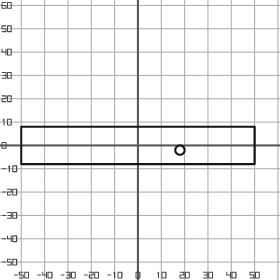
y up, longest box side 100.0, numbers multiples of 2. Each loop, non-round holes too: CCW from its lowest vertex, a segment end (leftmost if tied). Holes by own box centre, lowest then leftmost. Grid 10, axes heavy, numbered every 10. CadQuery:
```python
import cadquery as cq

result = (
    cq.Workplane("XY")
    .moveTo(-50.0, -8.0)
    .lineTo(50.0, -8.0)
    .lineTo(50.0, 8.0)
    .lineTo(-50.0, 8.0)
    .close()
    .moveTo(18.0, -2.0)
    .circle(2.0)
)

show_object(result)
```